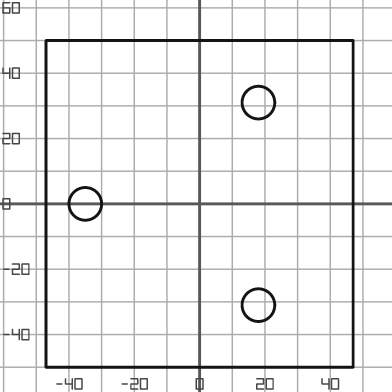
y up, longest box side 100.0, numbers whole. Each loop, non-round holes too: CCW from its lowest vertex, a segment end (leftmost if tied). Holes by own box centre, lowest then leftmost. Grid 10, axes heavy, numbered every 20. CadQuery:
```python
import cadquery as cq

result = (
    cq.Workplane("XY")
    .moveTo(-47.0, -50.0)
    .lineTo(47.0, -50.0)
    .lineTo(47.0, 50.0)
    .lineTo(-47.0, 50.0)
    .close()
    .moveTo(18.0, -31.0)
    .circle(5.0)
    .moveTo(-35.0, 0.0)
    .circle(5.0)
    .moveTo(18.0, 31.0)
    .circle(5.0)
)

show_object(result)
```